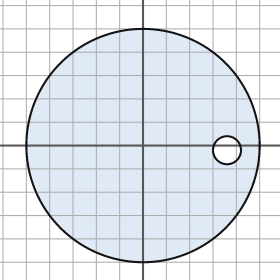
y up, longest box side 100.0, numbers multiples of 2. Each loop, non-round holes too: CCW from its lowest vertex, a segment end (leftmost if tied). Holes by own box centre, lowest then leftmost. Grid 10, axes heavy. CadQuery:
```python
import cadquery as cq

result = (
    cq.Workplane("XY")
    .moveTo(0.0, 0.0)
    .circle(50.0)
    .moveTo(36.0, -2.0)
    .circle(6.0)
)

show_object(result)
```